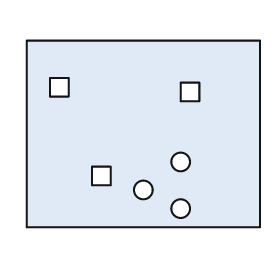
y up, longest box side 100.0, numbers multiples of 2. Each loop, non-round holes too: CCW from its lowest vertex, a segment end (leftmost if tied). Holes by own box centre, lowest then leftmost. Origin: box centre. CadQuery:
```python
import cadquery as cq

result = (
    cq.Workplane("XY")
    .moveTo(-50.0, -40.0)
    .lineTo(50.0, -40.0)
    .lineTo(50.0, 40.0)
    .lineTo(-50.0, 40.0)
    .close()
    .moveTo(16.0, -32.0)
    .circle(4.0)
    .moveTo(0.0, -24.0)
    .circle(4.0)
    .moveTo(-22.0, -22.0)
    .lineTo(-14.0, -22.0)
    .lineTo(-14.0, -14.0)
    .lineTo(-22.0, -14.0)
    .close()
    .moveTo(16.0, -12.0)
    .circle(4.0)
    .moveTo(16.0, 14.0)
    .lineTo(24.0, 14.0)
    .lineTo(24.0, 22.0)
    .lineTo(16.0, 22.0)
    .close()
    .moveTo(-40.0, 16.0)
    .lineTo(-32.0, 16.0)
    .lineTo(-32.0, 24.0)
    .lineTo(-40.0, 24.0)
    .close()
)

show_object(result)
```